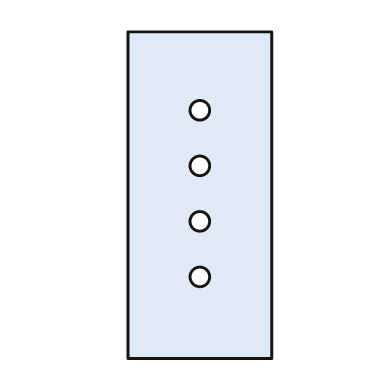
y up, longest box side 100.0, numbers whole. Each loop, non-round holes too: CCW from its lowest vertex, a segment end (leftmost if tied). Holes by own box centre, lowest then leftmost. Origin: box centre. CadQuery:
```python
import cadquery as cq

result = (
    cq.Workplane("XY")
    .moveTo(-22.0, -50.0)
    .lineTo(22.0, -50.0)
    .lineTo(22.0, 50.0)
    .lineTo(-22.0, 50.0)
    .close()
    .moveTo(0.0, -25.0)
    .circle(3.0)
    .moveTo(0.0, -8.0)
    .circle(3.0)
    .moveTo(0.0, 9.0)
    .circle(3.0)
    .moveTo(0.0, 26.0)
    .circle(3.0)
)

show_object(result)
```